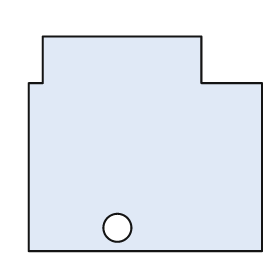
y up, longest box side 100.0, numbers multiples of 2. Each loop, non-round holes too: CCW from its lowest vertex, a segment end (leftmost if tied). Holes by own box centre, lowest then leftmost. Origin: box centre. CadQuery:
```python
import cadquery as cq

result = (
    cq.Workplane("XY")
    .moveTo(-50.0, -46.0)
    .lineTo(50.0, -46.0)
    .lineTo(50.0, 26.0)
    .lineTo(24.0, 26.0)
    .lineTo(24.0, 46.0)
    .lineTo(-44.0, 46.0)
    .lineTo(-44.0, 26.0)
    .lineTo(-50.0, 26.0)
    .close()
    .moveTo(-12.0, -36.0)
    .circle(6.0)
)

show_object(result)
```